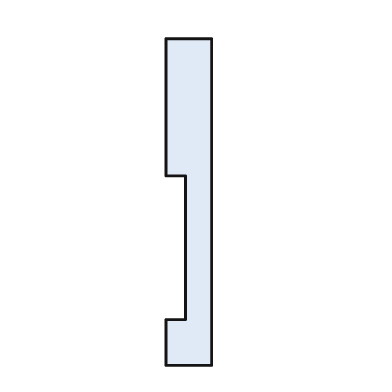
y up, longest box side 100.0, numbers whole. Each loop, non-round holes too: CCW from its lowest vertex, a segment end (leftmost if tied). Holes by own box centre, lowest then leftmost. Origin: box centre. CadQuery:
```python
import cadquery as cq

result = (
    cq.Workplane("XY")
    .moveTo(-7.0, -50.0)
    .lineTo(7.0, -50.0)
    .lineTo(7.0, 50.0)
    .lineTo(-7.0, 50.0)
    .lineTo(-7.0, 8.0)
    .lineTo(-1.0, 8.0)
    .lineTo(-1.0, -36.0)
    .lineTo(-7.0, -36.0)
    .close()
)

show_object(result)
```